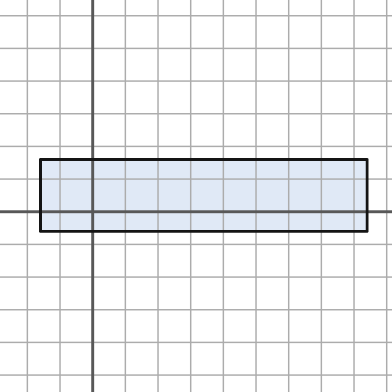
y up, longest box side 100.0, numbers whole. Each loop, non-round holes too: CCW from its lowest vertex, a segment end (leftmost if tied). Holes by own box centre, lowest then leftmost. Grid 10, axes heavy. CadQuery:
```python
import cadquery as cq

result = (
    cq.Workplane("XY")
    .moveTo(-16.0, -6.0)
    .lineTo(84.0, -6.0)
    .lineTo(84.0, 16.0)
    .lineTo(-16.0, 16.0)
    .close()
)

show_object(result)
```